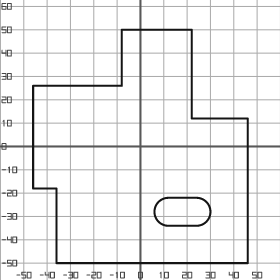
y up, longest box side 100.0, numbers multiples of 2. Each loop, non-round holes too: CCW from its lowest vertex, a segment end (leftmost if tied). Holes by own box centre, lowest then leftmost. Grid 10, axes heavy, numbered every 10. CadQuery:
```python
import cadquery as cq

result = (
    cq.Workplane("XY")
    .moveTo(-36.0, -50.0)
    .lineTo(46.0, -50.0)
    .lineTo(46.0, 12.0)
    .lineTo(22.0, 12.0)
    .lineTo(22.0, 50.0)
    .lineTo(-8.0, 50.0)
    .lineTo(-8.0, 26.0)
    .lineTo(-46.0, 26.0)
    .lineTo(-46.0, -18.0)
    .lineTo(-36.0, -18.0)
    .close()
    .moveTo(12.0, -34.0)
    .lineTo(24.0, -34.0)
    .threePointArc((30.0, -28.0), (24.0, -22.0))
    .lineTo(12.0, -22.0)
    .threePointArc((6.0, -28.0), (12.0, -34.0))
    .close()
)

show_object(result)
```